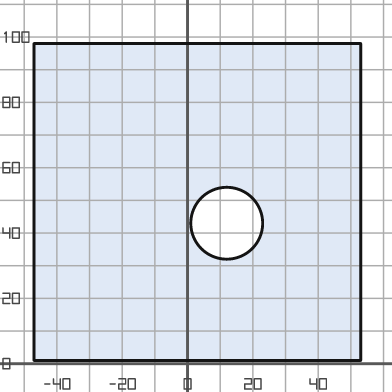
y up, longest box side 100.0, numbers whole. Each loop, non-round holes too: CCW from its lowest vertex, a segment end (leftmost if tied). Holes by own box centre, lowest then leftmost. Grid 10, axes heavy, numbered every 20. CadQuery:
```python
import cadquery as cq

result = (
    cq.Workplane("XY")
    .moveTo(-47.0, 1.0)
    .lineTo(53.0, 1.0)
    .lineTo(53.0, 98.0)
    .lineTo(-47.0, 98.0)
    .close()
    .moveTo(12.0, 43.0)
    .circle(11.0)
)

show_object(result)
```